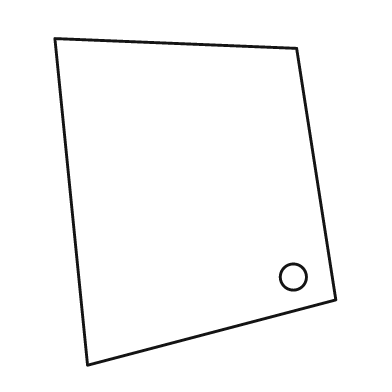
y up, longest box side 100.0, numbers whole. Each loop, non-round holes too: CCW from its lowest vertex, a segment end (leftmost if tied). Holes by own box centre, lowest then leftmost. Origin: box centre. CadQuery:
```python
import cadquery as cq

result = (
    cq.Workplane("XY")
    .moveTo(-33.0, -50.0)
    .lineTo(43.0, -30.0)
    .lineTo(31.0, 47.0)
    .lineTo(-43.0, 50.0)
    .close()
    .moveTo(30.0, -23.0)
    .circle(4.0)
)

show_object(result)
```